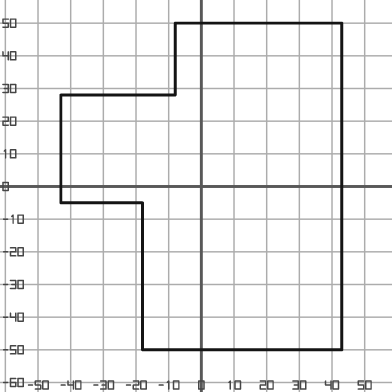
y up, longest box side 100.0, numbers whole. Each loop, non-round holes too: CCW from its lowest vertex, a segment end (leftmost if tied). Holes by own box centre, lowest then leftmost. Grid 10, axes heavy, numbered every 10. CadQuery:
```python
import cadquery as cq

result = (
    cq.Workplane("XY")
    .moveTo(-18.0, -50.0)
    .lineTo(43.0, -50.0)
    .lineTo(43.0, 50.0)
    .lineTo(-8.0, 50.0)
    .lineTo(-8.0, 28.0)
    .lineTo(-43.0, 28.0)
    .lineTo(-43.0, -5.0)
    .lineTo(-18.0, -5.0)
    .close()
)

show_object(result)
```